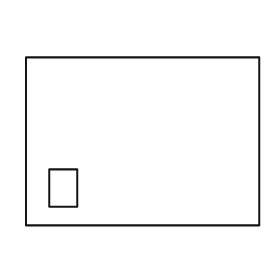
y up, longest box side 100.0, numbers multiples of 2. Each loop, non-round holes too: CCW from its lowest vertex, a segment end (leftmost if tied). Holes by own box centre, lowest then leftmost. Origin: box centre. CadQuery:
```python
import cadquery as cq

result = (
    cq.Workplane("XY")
    .moveTo(-50.0, -36.0)
    .lineTo(50.0, -36.0)
    .lineTo(50.0, 36.0)
    .lineTo(-50.0, 36.0)
    .close()
    .moveTo(-40.0, -28.0)
    .lineTo(-28.0, -28.0)
    .lineTo(-28.0, -12.0)
    .lineTo(-40.0, -12.0)
    .close()
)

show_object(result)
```